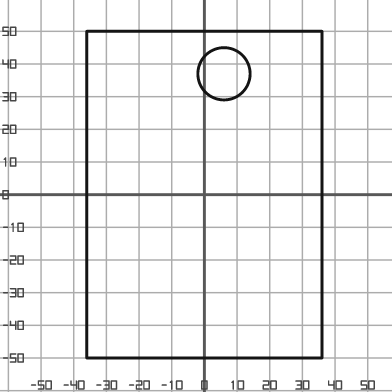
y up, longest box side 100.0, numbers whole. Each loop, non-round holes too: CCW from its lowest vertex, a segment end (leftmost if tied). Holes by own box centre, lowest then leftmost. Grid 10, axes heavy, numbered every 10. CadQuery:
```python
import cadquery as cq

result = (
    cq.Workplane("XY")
    .moveTo(-36.0, -50.0)
    .lineTo(36.0, -50.0)
    .lineTo(36.0, 50.0)
    .lineTo(-36.0, 50.0)
    .close()
    .moveTo(6.0, 37.0)
    .circle(8.0)
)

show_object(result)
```